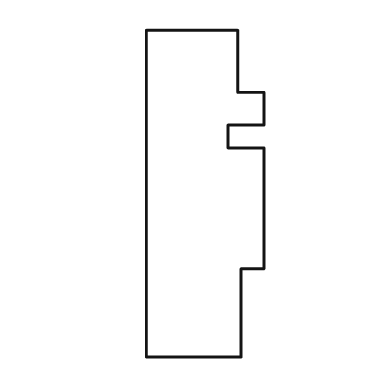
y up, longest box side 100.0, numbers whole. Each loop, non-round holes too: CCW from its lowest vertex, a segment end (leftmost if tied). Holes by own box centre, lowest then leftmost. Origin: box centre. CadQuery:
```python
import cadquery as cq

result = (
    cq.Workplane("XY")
    .moveTo(-18.0, -50.0)
    .lineTo(11.0, -50.0)
    .lineTo(11.0, -23.0)
    .lineTo(18.0, -23.0)
    .lineTo(18.0, 14.0)
    .lineTo(7.0, 14.0)
    .lineTo(7.0, 21.0)
    .lineTo(18.0, 21.0)
    .lineTo(18.0, 31.0)
    .lineTo(10.0, 31.0)
    .lineTo(10.0, 50.0)
    .lineTo(-18.0, 50.0)
    .close()
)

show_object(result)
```